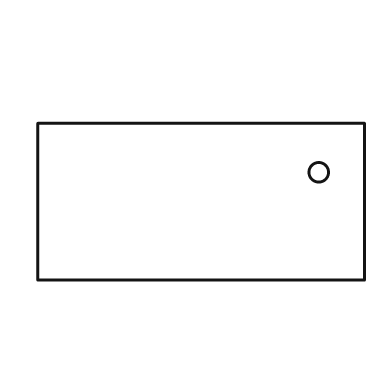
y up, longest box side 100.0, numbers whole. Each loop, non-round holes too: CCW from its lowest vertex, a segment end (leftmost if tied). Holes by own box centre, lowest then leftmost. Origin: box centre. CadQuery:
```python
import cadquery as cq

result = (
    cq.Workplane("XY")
    .moveTo(-50.0, -24.0)
    .lineTo(50.0, -24.0)
    .lineTo(50.0, 24.0)
    .lineTo(-50.0, 24.0)
    .close()
    .moveTo(36.0, 9.0)
    .circle(3.0)
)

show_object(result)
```